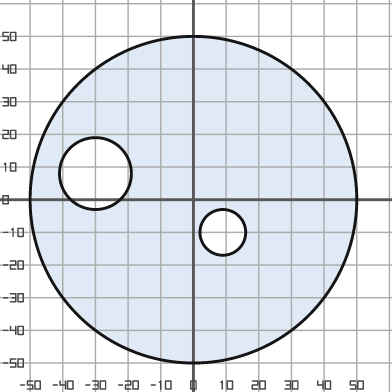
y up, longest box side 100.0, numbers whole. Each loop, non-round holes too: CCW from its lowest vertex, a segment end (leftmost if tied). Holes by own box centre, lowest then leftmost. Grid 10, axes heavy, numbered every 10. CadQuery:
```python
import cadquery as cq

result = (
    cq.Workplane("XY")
    .moveTo(0.0, 0.0)
    .circle(50.0)
    .moveTo(9.0, -10.0)
    .circle(7.0)
    .moveTo(-30.0, 8.0)
    .circle(11.0)
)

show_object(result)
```